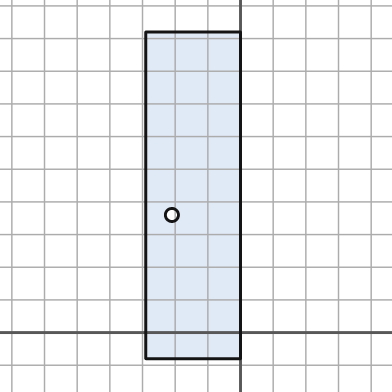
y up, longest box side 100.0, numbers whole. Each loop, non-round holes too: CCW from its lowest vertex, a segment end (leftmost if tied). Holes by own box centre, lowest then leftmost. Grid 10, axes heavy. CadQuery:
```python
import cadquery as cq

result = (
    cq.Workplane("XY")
    .moveTo(-29.0, -8.0)
    .lineTo(0.0, -8.0)
    .lineTo(0.0, 92.0)
    .lineTo(-29.0, 92.0)
    .close()
    .moveTo(-21.0, 36.0)
    .circle(2.0)
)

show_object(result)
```